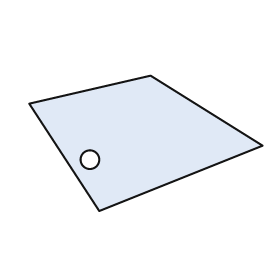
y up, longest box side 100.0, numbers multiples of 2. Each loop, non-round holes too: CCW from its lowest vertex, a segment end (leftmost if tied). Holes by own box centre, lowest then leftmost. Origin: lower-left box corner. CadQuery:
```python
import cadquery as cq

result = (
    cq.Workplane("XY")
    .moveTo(30.0, 0.0)
    .lineTo(100.0, 28.0)
    .lineTo(52.0, 58.0)
    .lineTo(0.0, 46.0)
    .close()
    .moveTo(26.0, 22.0)
    .circle(4.0)
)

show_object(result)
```